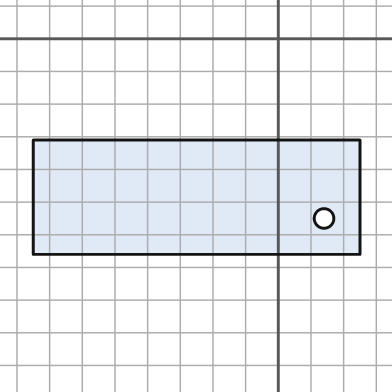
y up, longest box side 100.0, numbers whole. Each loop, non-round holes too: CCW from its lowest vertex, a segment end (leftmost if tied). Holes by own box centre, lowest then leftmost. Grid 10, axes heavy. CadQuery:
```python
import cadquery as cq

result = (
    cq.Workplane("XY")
    .moveTo(-75.0, -66.0)
    .lineTo(25.0, -66.0)
    .lineTo(25.0, -31.0)
    .lineTo(-75.0, -31.0)
    .close()
    .moveTo(14.0, -55.0)
    .circle(3.0)
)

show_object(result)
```